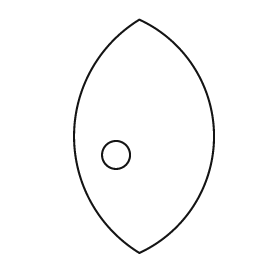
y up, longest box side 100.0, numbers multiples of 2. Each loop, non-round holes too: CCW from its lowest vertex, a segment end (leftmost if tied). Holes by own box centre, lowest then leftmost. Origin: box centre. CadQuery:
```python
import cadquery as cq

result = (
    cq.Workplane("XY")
    .moveTo(-2.0, -50.0)
    .threePointArc((30.0, 0.0), (-2.0, 50.0))
    .threePointArc((-30.0, 0.0), (-2.0, -50.0))
    .close()
    .moveTo(-12.0, -8.0)
    .circle(6.0)
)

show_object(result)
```